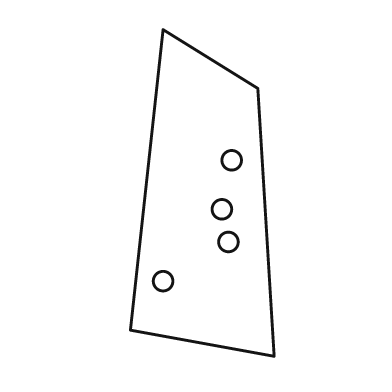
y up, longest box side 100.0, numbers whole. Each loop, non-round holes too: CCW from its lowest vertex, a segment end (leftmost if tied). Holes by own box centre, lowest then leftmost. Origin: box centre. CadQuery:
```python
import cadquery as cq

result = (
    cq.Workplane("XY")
    .moveTo(22.0, -50.0)
    .lineTo(17.0, 32.0)
    .lineTo(-12.0, 50.0)
    .lineTo(-22.0, -42.0)
    .close()
    .moveTo(-12.0, -27.0)
    .circle(3.0)
    .moveTo(8.0, -15.0)
    .circle(3.0)
    .moveTo(6.0, -5.0)
    .circle(3.0)
    .moveTo(9.0, 10.0)
    .circle(3.0)
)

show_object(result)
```